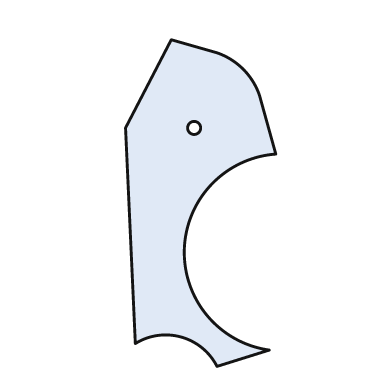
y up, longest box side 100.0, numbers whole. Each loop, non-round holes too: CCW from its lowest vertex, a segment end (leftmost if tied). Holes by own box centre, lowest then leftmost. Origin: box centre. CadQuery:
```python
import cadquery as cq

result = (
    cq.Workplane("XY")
    .moveTo(5.0, -50.0)
    .lineTo(21.0, -45.0)
    .threePointArc((-5.0, -14.0), (23.0, 15.0))
    .lineTo(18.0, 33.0)
    .threePointArc((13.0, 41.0), (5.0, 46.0))
    .lineTo(-9.0, 50.0)
    .lineTo(-23.0, 23.0)
    .lineTo(-20.0, -43.0)
    .threePointArc((-6.0, -41.0), (5.0, -50.0))
    .close()
    .moveTo(-2.0, 23.0)
    .circle(2.0)
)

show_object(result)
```